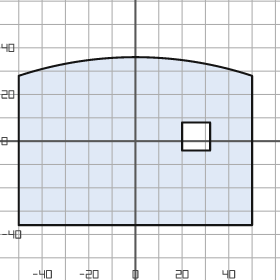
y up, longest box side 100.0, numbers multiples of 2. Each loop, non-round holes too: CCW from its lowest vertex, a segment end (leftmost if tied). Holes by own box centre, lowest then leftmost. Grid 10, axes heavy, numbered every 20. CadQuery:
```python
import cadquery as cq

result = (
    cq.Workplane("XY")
    .moveTo(-50.0, -36.0)
    .lineTo(50.0, -36.0)
    .lineTo(50.0, 28.0)
    .threePointArc((0.0, 36.0), (-50.0, 28.0))
    .close()
    .moveTo(20.0, -4.0)
    .lineTo(32.0, -4.0)
    .lineTo(32.0, 8.0)
    .lineTo(20.0, 8.0)
    .close()
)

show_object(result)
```